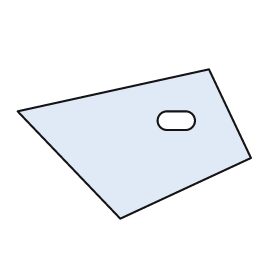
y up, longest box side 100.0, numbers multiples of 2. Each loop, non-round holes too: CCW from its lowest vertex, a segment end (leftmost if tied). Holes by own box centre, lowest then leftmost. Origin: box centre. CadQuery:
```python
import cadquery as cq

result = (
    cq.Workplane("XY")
    .moveTo(-6.0, -32.0)
    .lineTo(50.0, -6.0)
    .lineTo(32.0, 32.0)
    .lineTo(-50.0, 14.0)
    .close()
    .moveTo(14.0, 6.0)
    .lineTo(22.0, 6.0)
    .threePointArc((26.0, 10.0), (22.0, 14.0))
    .lineTo(14.0, 14.0)
    .threePointArc((10.0, 10.0), (14.0, 6.0))
    .close()
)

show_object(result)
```